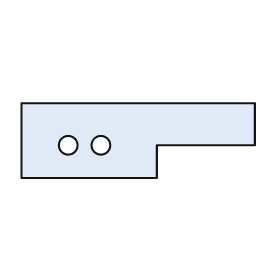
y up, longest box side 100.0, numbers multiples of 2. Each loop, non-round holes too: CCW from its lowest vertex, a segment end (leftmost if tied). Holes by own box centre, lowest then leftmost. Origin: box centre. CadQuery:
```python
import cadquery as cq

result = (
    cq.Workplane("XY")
    .moveTo(-50.0, -16.0)
    .lineTo(8.0, -16.0)
    .lineTo(8.0, -2.0)
    .lineTo(50.0, -2.0)
    .lineTo(50.0, 16.0)
    .lineTo(-50.0, 16.0)
    .close()
    .moveTo(-30.0, -2.0)
    .circle(4.0)
    .moveTo(-16.0, -2.0)
    .circle(4.0)
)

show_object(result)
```